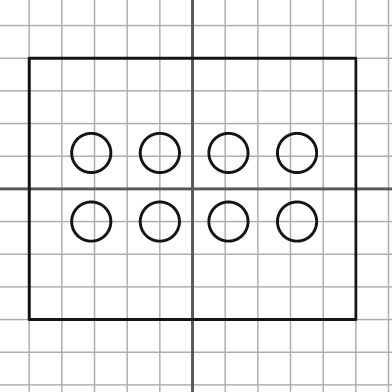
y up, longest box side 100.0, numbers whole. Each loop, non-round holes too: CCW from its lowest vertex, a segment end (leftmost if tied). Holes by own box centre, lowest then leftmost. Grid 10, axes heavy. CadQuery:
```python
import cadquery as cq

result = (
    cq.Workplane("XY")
    .moveTo(-50.0, -40.0)
    .lineTo(50.0, -40.0)
    .lineTo(50.0, 40.0)
    .lineTo(-50.0, 40.0)
    .close()
    .moveTo(-31.0, -10.0)
    .circle(6.0)
    .moveTo(-10.0, -10.0)
    .circle(6.0)
    .moveTo(11.0, -10.0)
    .circle(6.0)
    .moveTo(32.0, -10.0)
    .circle(6.0)
    .moveTo(-31.0, 11.0)
    .circle(6.0)
    .moveTo(-10.0, 11.0)
    .circle(6.0)
    .moveTo(11.0, 11.0)
    .circle(6.0)
    .moveTo(32.0, 11.0)
    .circle(6.0)
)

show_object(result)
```